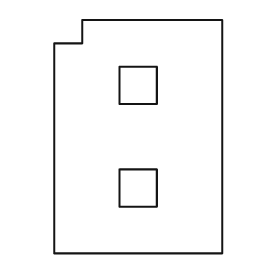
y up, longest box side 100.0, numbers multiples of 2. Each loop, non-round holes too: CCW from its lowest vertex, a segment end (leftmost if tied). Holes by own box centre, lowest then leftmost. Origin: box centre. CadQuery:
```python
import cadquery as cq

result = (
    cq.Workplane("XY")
    .moveTo(-36.0, -50.0)
    .lineTo(36.0, -50.0)
    .lineTo(36.0, 50.0)
    .lineTo(-24.0, 50.0)
    .lineTo(-24.0, 40.0)
    .lineTo(-36.0, 40.0)
    .close()
    .moveTo(-8.0, -30.0)
    .lineTo(8.0, -30.0)
    .lineTo(8.0, -14.0)
    .lineTo(-8.0, -14.0)
    .close()
    .moveTo(-8.0, 14.0)
    .lineTo(8.0, 14.0)
    .lineTo(8.0, 30.0)
    .lineTo(-8.0, 30.0)
    .close()
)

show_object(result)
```